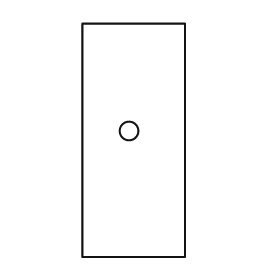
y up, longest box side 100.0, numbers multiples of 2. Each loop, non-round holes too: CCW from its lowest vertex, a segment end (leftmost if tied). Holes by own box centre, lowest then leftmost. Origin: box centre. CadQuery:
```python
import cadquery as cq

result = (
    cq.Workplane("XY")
    .moveTo(-22.0, -50.0)
    .lineTo(22.0, -50.0)
    .lineTo(22.0, 50.0)
    .lineTo(-22.0, 50.0)
    .close()
    .moveTo(-2.0, 4.0)
    .circle(4.0)
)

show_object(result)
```